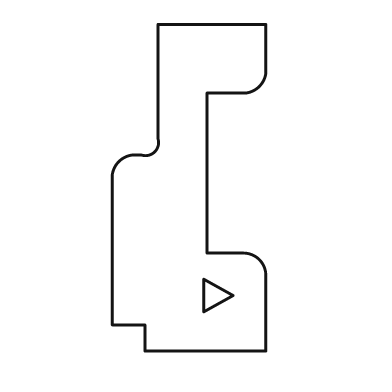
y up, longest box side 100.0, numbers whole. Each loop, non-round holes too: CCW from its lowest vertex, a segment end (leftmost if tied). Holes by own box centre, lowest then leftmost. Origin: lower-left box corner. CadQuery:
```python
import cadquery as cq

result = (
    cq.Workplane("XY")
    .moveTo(10.0, 0.0)
    .lineTo(47.0, 0.0)
    .lineTo(47.0, 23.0)
    .threePointArc((45.0, 28.0), (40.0, 30.0))
    .lineTo(29.0, 30.0)
    .lineTo(29.0, 79.0)
    .lineTo(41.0, 79.0)
    .threePointArc((45.0, 81.0), (47.0, 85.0))
    .lineTo(47.0, 100.0)
    .lineTo(14.0, 100.0)
    .lineTo(14.0, 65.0)
    .threePointArc((13.0, 61.0), (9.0, 60.0))
    .lineTo(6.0, 60.0)
    .threePointArc((2.0, 58.0), (0.0, 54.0))
    .lineTo(0.0, 8.0)
    .lineTo(10.0, 8.0)
    .close()
    .moveTo(28.0, 12.0)
    .lineTo(37.0, 17.0)
    .lineTo(28.0, 22.0)
    .close()
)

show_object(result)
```